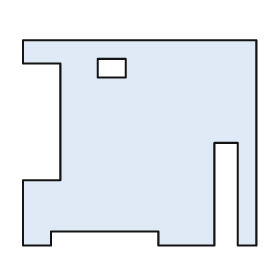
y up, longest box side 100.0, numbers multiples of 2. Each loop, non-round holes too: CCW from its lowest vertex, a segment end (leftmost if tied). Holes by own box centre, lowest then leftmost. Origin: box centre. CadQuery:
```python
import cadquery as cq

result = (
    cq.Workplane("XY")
    .moveTo(-50.0, -44.0)
    .lineTo(-38.0, -44.0)
    .lineTo(-38.0, -38.0)
    .lineTo(8.0, -38.0)
    .lineTo(8.0, -44.0)
    .lineTo(32.0, -44.0)
    .lineTo(32.0, 0.0)
    .lineTo(42.0, 0.0)
    .lineTo(42.0, -44.0)
    .lineTo(50.0, -44.0)
    .lineTo(50.0, 44.0)
    .lineTo(-50.0, 44.0)
    .lineTo(-50.0, 34.0)
    .lineTo(-34.0, 34.0)
    .lineTo(-34.0, -16.0)
    .lineTo(-50.0, -16.0)
    .close()
    .moveTo(-18.0, 28.0)
    .lineTo(-6.0, 28.0)
    .lineTo(-6.0, 36.0)
    .lineTo(-18.0, 36.0)
    .close()
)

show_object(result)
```